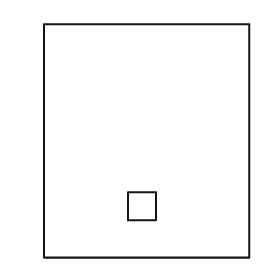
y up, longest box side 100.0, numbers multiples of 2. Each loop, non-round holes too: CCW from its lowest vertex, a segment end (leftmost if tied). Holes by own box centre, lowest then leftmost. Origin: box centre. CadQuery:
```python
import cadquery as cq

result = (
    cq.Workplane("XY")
    .moveTo(-44.0, -50.0)
    .lineTo(44.0, -50.0)
    .lineTo(44.0, 50.0)
    .lineTo(-44.0, 50.0)
    .close()
    .moveTo(-8.0, -34.0)
    .lineTo(4.0, -34.0)
    .lineTo(4.0, -22.0)
    .lineTo(-8.0, -22.0)
    .close()
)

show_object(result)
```